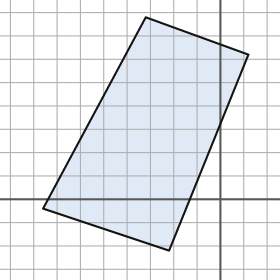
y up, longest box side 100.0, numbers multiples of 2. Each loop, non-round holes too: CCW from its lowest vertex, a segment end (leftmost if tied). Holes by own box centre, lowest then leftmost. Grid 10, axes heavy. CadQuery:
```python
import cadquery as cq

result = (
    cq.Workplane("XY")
    .moveTo(-22.0, -22.0)
    .lineTo(12.0, 62.0)
    .lineTo(-32.0, 78.0)
    .lineTo(-76.0, -4.0)
    .close()
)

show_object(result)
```